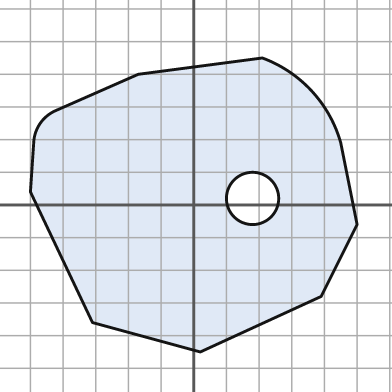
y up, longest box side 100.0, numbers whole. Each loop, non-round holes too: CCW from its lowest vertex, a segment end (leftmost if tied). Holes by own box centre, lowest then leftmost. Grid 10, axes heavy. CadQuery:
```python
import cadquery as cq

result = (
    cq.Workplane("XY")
    .moveTo(2.0, -45.0)
    .lineTo(39.0, -28.0)
    .lineTo(50.0, -6.0)
    .lineTo(45.0, 19.0)
    .threePointArc((36.0, 35.0), (21.0, 45.0))
    .lineTo(-17.0, 40.0)
    .lineTo(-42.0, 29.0)
    .threePointArc((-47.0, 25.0), (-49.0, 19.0))
    .lineTo(-50.0, 4.0)
    .lineTo(-31.0, -36.0)
    .close()
    .moveTo(18.0, 2.0)
    .circle(8.0)
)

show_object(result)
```